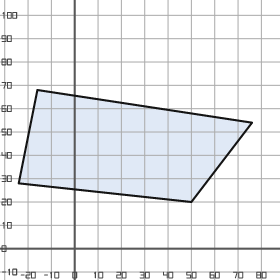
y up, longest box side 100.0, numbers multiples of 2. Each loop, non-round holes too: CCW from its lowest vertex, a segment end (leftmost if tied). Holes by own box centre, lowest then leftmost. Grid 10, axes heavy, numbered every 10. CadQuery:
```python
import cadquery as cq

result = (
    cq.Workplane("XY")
    .moveTo(50.0, 20.0)
    .lineTo(76.0, 54.0)
    .lineTo(-16.0, 68.0)
    .lineTo(-24.0, 28.0)
    .close()
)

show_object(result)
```